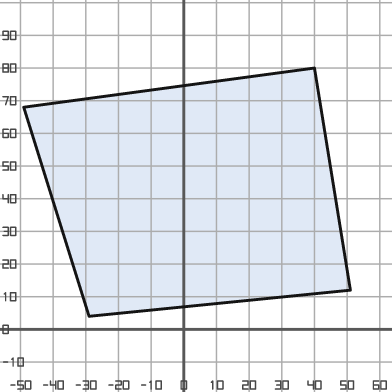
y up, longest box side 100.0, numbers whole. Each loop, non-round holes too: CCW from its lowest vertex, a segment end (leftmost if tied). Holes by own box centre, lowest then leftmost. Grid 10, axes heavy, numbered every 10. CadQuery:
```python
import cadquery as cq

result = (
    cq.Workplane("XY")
    .moveTo(-29.0, 4.0)
    .lineTo(51.0, 12.0)
    .lineTo(40.0, 80.0)
    .lineTo(-49.0, 68.0)
    .close()
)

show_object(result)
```